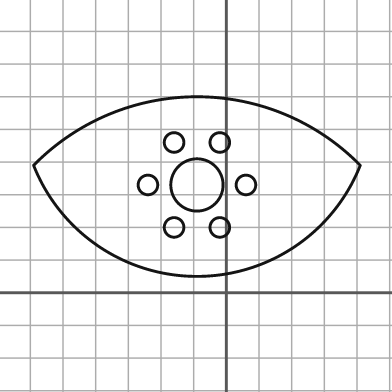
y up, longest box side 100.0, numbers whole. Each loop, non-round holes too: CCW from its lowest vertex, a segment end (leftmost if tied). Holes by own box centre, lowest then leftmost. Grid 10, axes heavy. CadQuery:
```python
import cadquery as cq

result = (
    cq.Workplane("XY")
    .moveTo(-59.0, 39.0)
    .threePointArc((-9.0, 5.0), (41.0, 39.0))
    .threePointArc((-9.0, 60.0), (-59.0, 39.0))
    .close()
    .moveTo(-16.0, 20.0)
    .circle(3.0)
    .moveTo(-2.0, 20.0)
    .circle(3.0)
    .moveTo(-24.0, 33.0)
    .circle(3.0)
    .moveTo(-9.0, 33.0)
    .circle(8.0)
    .moveTo(6.0, 33.0)
    .circle(3.0)
    .moveTo(-16.0, 46.0)
    .circle(3.0)
    .moveTo(-2.0, 46.0)
    .circle(3.0)
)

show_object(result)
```